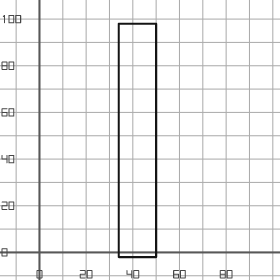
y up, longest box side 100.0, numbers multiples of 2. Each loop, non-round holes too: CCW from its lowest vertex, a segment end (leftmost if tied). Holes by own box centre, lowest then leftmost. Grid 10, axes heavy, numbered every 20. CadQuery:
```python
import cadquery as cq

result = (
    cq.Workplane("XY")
    .moveTo(34.0, -2.0)
    .lineTo(50.0, -2.0)
    .lineTo(50.0, 98.0)
    .lineTo(34.0, 98.0)
    .close()
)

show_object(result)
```